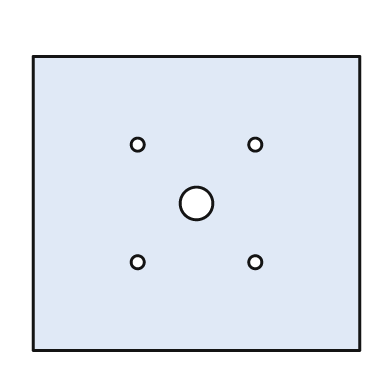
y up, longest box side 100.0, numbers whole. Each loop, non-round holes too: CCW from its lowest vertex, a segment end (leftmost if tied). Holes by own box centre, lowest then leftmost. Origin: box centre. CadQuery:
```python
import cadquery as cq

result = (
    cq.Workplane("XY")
    .moveTo(-50.0, -45.0)
    .lineTo(50.0, -45.0)
    .lineTo(50.0, 45.0)
    .lineTo(-50.0, 45.0)
    .close()
    .moveTo(-18.0, -18.0)
    .circle(2.0)
    .moveTo(18.0, -18.0)
    .circle(2.0)
    .moveTo(0.0, 0.0)
    .circle(5.0)
    .moveTo(-18.0, 18.0)
    .circle(2.0)
    .moveTo(18.0, 18.0)
    .circle(2.0)
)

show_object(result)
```